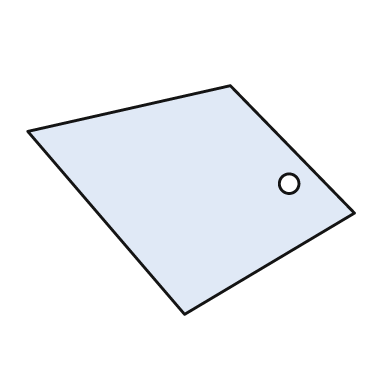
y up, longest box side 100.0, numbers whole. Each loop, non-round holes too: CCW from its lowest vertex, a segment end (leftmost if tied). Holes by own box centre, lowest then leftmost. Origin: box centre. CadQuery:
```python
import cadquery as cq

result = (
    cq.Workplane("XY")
    .moveTo(-2.0, -35.0)
    .lineTo(50.0, -4.0)
    .lineTo(12.0, 35.0)
    .lineTo(-50.0, 21.0)
    .close()
    .moveTo(30.0, 5.0)
    .circle(3.0)
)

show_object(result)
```